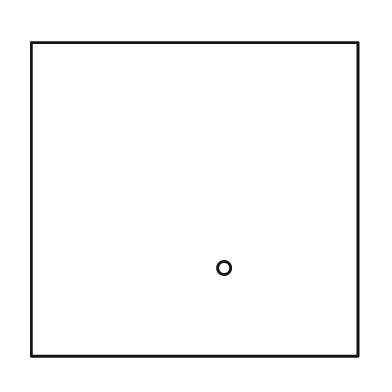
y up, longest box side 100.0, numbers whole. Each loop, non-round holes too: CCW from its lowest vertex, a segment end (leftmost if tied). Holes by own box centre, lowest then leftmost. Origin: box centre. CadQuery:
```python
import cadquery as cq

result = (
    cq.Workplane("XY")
    .moveTo(-50.0, -48.0)
    .lineTo(50.0, -48.0)
    .lineTo(50.0, 48.0)
    .lineTo(-50.0, 48.0)
    .close()
    .moveTo(9.0, -21.0)
    .circle(2.0)
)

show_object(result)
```